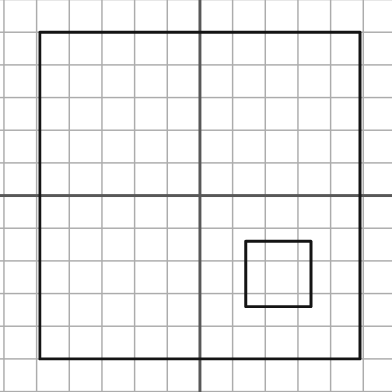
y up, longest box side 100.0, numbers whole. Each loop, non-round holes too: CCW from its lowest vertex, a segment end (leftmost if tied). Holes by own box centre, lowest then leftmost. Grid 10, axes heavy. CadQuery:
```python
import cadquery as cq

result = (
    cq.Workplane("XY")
    .moveTo(-49.0, -50.0)
    .lineTo(49.0, -50.0)
    .lineTo(49.0, 50.0)
    .lineTo(-49.0, 50.0)
    .close()
    .moveTo(14.0, -34.0)
    .lineTo(34.0, -34.0)
    .lineTo(34.0, -14.0)
    .lineTo(14.0, -14.0)
    .close()
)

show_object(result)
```